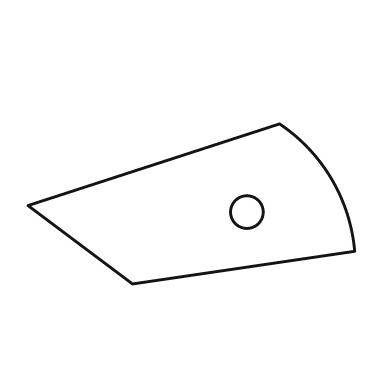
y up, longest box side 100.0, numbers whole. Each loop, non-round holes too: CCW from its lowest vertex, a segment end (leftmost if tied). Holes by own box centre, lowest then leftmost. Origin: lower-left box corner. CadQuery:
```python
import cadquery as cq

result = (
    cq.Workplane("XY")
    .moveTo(32.0, 0.0)
    .lineTo(100.0, 10.0)
    .threePointArc((93.0, 32.0), (77.0, 49.0))
    .lineTo(0.0, 24.0)
    .close()
    .moveTo(67.0, 22.0)
    .circle(5.0)
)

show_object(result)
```